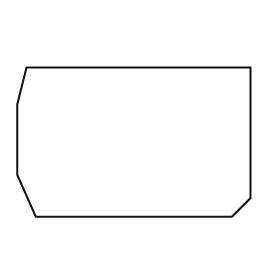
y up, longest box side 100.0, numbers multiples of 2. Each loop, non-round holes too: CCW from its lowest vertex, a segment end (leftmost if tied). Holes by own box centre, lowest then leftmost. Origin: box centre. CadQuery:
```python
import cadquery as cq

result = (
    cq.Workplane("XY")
    .moveTo(-42.0, -32.0)
    .lineTo(42.0, -32.0)
    .lineTo(50.0, -24.0)
    .lineTo(50.0, 32.0)
    .lineTo(-46.0, 32.0)
    .lineTo(-50.0, 16.0)
    .lineTo(-50.0, -14.0)
    .close()
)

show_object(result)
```